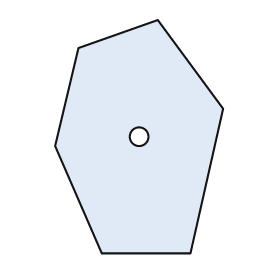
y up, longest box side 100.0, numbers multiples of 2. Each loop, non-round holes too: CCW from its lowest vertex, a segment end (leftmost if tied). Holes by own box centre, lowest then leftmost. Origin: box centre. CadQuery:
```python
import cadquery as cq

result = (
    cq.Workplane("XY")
    .moveTo(-16.0, -50.0)
    .lineTo(22.0, -50.0)
    .lineTo(36.0, 12.0)
    .lineTo(8.0, 50.0)
    .lineTo(-26.0, 38.0)
    .lineTo(-36.0, -4.0)
    .close()
    .moveTo(0.0, 0.0)
    .circle(4.0)
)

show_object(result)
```